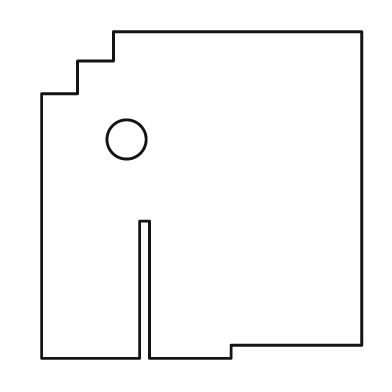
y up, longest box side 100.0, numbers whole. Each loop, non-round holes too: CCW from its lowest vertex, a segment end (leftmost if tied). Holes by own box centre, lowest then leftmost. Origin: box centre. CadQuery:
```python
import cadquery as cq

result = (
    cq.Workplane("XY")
    .moveTo(-49.0, -50.0)
    .lineTo(-19.0, -50.0)
    .lineTo(-19.0, -8.0)
    .lineTo(-16.0, -8.0)
    .lineTo(-16.0, -50.0)
    .lineTo(9.0, -50.0)
    .lineTo(9.0, -46.0)
    .lineTo(49.0, -46.0)
    .lineTo(49.0, 50.0)
    .lineTo(-27.0, 50.0)
    .lineTo(-27.0, 41.0)
    .lineTo(-38.0, 41.0)
    .lineTo(-38.0, 31.0)
    .lineTo(-49.0, 31.0)
    .close()
    .moveTo(-23.0, 17.0)
    .circle(6.0)
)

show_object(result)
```